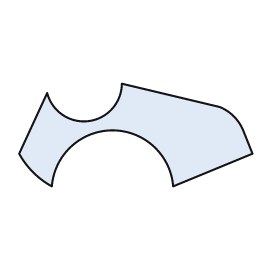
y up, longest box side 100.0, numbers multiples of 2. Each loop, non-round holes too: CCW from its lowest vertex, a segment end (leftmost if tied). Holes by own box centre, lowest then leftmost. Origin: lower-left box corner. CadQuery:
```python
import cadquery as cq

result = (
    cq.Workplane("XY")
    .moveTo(14.0, 0.0)
    .threePointArc((40.0, 24.0), (66.0, 0.0))
    .lineTo(100.0, 14.0)
    .lineTo(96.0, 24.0)
    .threePointArc((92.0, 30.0), (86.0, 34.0))
    .lineTo(44.0, 44.0)
    .threePointArc((30.0, 28.0), (12.0, 40.0))
    .lineTo(0.0, 14.0)
    .threePointArc((6.0, 6.0), (14.0, 0.0))
    .close()
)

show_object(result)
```